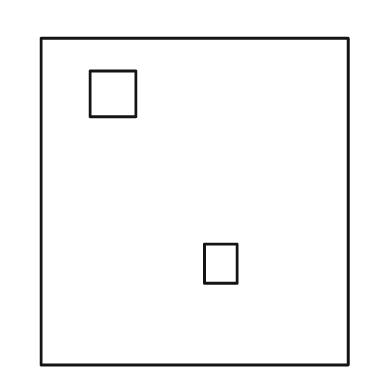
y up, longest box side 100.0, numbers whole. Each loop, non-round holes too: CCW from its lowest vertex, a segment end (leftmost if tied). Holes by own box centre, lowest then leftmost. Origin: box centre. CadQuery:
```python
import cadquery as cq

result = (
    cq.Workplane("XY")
    .moveTo(-47.0, -50.0)
    .lineTo(47.0, -50.0)
    .lineTo(47.0, 50.0)
    .lineTo(-47.0, 50.0)
    .close()
    .moveTo(3.0, -25.0)
    .lineTo(13.0, -25.0)
    .lineTo(13.0, -13.0)
    .lineTo(3.0, -13.0)
    .close()
    .moveTo(-32.0, 26.0)
    .lineTo(-18.0, 26.0)
    .lineTo(-18.0, 40.0)
    .lineTo(-32.0, 40.0)
    .close()
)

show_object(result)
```